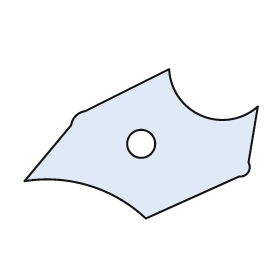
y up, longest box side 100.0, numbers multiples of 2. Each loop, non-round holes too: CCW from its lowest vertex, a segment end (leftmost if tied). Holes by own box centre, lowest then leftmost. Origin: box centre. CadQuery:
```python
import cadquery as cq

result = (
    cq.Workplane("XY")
    .moveTo(2.0, -32.0)
    .lineTo(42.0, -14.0)
    .threePointArc((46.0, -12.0), (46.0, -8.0))
    .lineTo(50.0, 16.0)
    .threePointArc((26.0, 12.0), (12.0, 32.0))
    .lineTo(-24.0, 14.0)
    .threePointArc((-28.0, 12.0), (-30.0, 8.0))
    .lineTo(-50.0, -16.0)
    .threePointArc((-22.0, -18.0), (2.0, -32.0))
    .close()
    .moveTo(0.0, 0.0)
    .circle(6.0)
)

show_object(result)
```